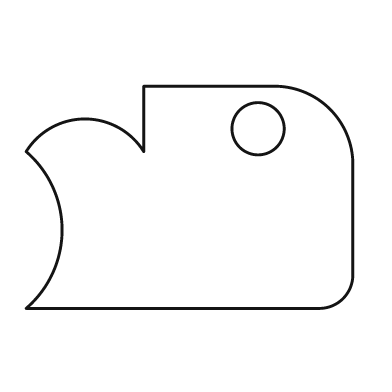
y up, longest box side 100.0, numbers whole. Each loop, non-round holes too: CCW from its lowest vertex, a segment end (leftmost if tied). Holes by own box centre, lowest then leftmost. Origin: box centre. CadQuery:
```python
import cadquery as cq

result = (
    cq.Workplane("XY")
    .moveTo(-50.0, -34.0)
    .lineTo(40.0, -34.0)
    .threePointArc((47.0, -31.0), (50.0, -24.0))
    .lineTo(50.0, 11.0)
    .threePointArc((43.0, 27.0), (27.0, 34.0))
    .lineTo(-14.0, 34.0)
    .lineTo(-14.0, 14.0)
    .threePointArc((-32.0, 24.0), (-50.0, 14.0))
    .threePointArc((-39.0, -10.0), (-50.0, -34.0))
    .close()
    .moveTo(21.0, 21.0)
    .circle(8.0)
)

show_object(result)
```